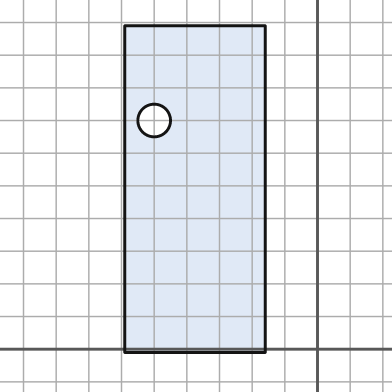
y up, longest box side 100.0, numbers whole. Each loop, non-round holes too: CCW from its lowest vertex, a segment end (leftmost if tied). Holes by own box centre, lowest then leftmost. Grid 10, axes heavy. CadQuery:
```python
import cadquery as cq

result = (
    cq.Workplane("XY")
    .moveTo(-59.0, -1.0)
    .lineTo(-16.0, -1.0)
    .lineTo(-16.0, 99.0)
    .lineTo(-59.0, 99.0)
    .close()
    .moveTo(-50.0, 70.0)
    .circle(5.0)
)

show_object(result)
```